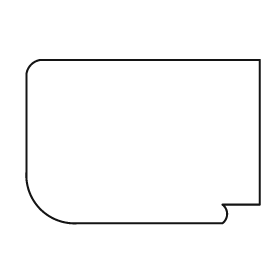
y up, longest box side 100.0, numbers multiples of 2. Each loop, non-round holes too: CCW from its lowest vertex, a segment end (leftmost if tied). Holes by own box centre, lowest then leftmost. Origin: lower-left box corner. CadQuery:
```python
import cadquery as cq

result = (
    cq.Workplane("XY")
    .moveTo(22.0, 0.0)
    .lineTo(84.0, 0.0)
    .threePointArc((86.0, 4.0), (84.0, 8.0))
    .lineTo(100.0, 8.0)
    .lineTo(100.0, 70.0)
    .lineTo(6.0, 70.0)
    .threePointArc((2.0, 68.0), (0.0, 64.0))
    .lineTo(0.0, 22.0)
    .threePointArc((6.0, 6.0), (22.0, 0.0))
    .close()
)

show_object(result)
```